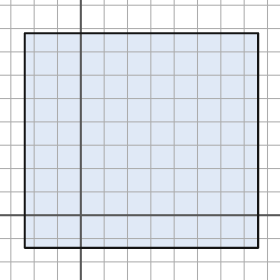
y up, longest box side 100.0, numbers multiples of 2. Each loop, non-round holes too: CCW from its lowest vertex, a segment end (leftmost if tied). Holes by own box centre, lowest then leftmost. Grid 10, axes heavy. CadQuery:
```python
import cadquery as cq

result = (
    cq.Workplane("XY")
    .moveTo(-24.0, -14.0)
    .lineTo(76.0, -14.0)
    .lineTo(76.0, 78.0)
    .lineTo(-24.0, 78.0)
    .close()
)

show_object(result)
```